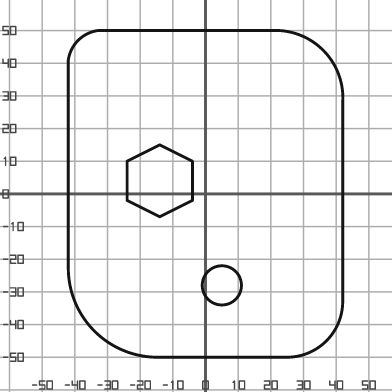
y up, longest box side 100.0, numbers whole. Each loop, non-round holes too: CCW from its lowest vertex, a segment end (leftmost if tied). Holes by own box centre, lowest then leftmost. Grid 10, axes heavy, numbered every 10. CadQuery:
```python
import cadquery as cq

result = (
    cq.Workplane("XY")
    .moveTo(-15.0, -50.0)
    .lineTo(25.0, -50.0)
    .threePointArc((37.0, -45.0), (42.0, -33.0))
    .lineTo(42.0, 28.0)
    .threePointArc((36.0, 44.0), (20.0, 50.0))
    .lineTo(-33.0, 50.0)
    .threePointArc((-39.0, 47.0), (-42.0, 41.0))
    .lineTo(-42.0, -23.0)
    .threePointArc((-34.0, -42.0), (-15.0, -50.0))
    .close()
    .moveTo(5.0, -28.0)
    .circle(6.0)
    .moveTo(-14.0, -7.0)
    .lineTo(-4.0, -2.0)
    .lineTo(-4.0, 10.0)
    .lineTo(-14.0, 15.0)
    .lineTo(-24.0, 10.0)
    .lineTo(-24.0, -2.0)
    .close()
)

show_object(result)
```